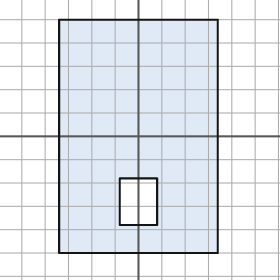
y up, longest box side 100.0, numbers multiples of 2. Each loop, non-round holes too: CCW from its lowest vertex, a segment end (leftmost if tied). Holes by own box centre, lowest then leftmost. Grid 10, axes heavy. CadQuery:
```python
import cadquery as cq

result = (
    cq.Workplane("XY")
    .moveTo(-34.0, -50.0)
    .lineTo(34.0, -50.0)
    .lineTo(34.0, 50.0)
    .lineTo(-34.0, 50.0)
    .close()
    .moveTo(-8.0, -38.0)
    .lineTo(8.0, -38.0)
    .lineTo(8.0, -18.0)
    .lineTo(-8.0, -18.0)
    .close()
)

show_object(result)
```